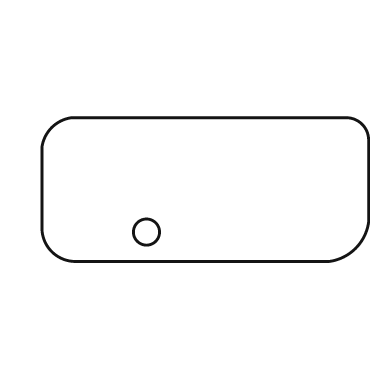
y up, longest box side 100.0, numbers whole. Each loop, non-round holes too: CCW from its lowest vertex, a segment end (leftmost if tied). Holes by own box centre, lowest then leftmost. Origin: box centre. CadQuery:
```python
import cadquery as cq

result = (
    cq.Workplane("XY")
    .moveTo(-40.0, -22.0)
    .lineTo(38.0, -22.0)
    .threePointArc((46.0, -18.0), (50.0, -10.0))
    .lineTo(50.0, 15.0)
    .threePointArc((48.0, 20.0), (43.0, 22.0))
    .lineTo(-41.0, 22.0)
    .threePointArc((-47.0, 19.0), (-50.0, 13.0))
    .lineTo(-50.0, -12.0)
    .threePointArc((-47.0, -19.0), (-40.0, -22.0))
    .close()
    .moveTo(-18.0, -13.0)
    .circle(4.0)
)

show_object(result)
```